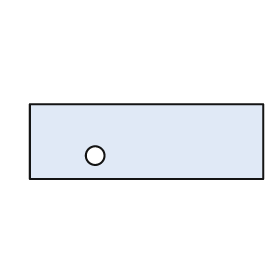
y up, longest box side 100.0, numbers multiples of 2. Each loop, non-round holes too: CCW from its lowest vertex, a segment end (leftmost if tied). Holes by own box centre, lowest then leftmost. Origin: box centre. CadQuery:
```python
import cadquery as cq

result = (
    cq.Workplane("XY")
    .moveTo(-50.0, -16.0)
    .lineTo(50.0, -16.0)
    .lineTo(50.0, 16.0)
    .lineTo(-50.0, 16.0)
    .close()
    .moveTo(-22.0, -6.0)
    .circle(4.0)
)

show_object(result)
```